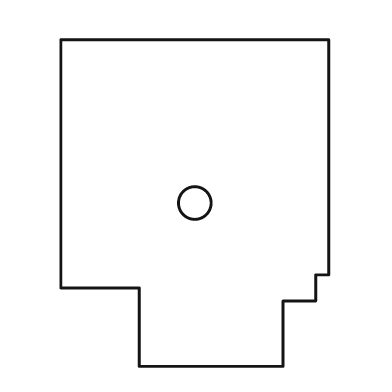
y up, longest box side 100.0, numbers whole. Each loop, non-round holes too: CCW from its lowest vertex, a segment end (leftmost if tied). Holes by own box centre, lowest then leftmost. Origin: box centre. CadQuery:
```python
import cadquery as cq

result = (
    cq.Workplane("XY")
    .moveTo(-17.0, -50.0)
    .lineTo(27.0, -50.0)
    .lineTo(27.0, -30.0)
    .lineTo(37.0, -30.0)
    .lineTo(37.0, -22.0)
    .lineTo(41.0, -22.0)
    .lineTo(41.0, 50.0)
    .lineTo(-41.0, 50.0)
    .lineTo(-41.0, -26.0)
    .lineTo(-17.0, -26.0)
    .close()
    .moveTo(0.0, 0.0)
    .circle(5.0)
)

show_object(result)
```